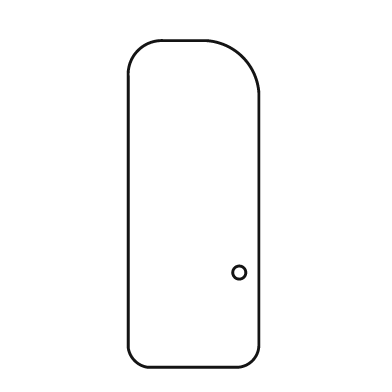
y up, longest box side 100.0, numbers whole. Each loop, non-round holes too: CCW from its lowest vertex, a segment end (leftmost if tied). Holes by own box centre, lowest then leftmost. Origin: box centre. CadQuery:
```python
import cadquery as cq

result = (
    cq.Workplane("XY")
    .moveTo(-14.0, -50.0)
    .lineTo(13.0, -50.0)
    .threePointArc((18.0, -48.0), (20.0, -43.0))
    .lineTo(20.0, 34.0)
    .threePointArc((15.0, 45.0), (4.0, 50.0))
    .lineTo(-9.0, 50.0)
    .threePointArc((-17.0, 47.0), (-20.0, 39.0))
    .lineTo(-20.0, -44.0)
    .threePointArc((-18.0, -48.0), (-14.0, -50.0))
    .close()
    .moveTo(14.0, -21.0)
    .circle(2.0)
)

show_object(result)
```